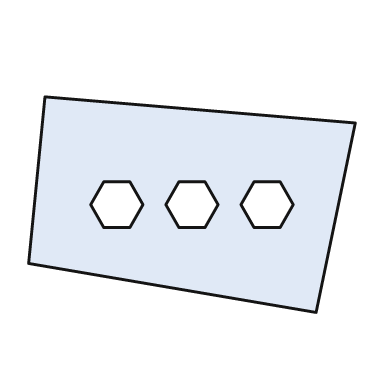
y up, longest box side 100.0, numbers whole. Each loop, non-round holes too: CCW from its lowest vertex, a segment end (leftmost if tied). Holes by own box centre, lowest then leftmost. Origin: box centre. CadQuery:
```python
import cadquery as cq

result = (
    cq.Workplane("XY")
    .moveTo(38.0, -33.0)
    .lineTo(50.0, 25.0)
    .lineTo(-45.0, 33.0)
    .lineTo(-50.0, -18.0)
    .close()
    .moveTo(-27.0, -7.0)
    .lineTo(-19.0, -7.0)
    .lineTo(-15.0, 0.0)
    .lineTo(-19.0, 7.0)
    .lineTo(-27.0, 7.0)
    .lineTo(-31.0, 0.0)
    .close()
    .moveTo(-4.0, -7.0)
    .lineTo(4.0, -7.0)
    .lineTo(8.0, 0.0)
    .lineTo(4.0, 7.0)
    .lineTo(-4.0, 7.0)
    .lineTo(-8.0, 0.0)
    .close()
    .moveTo(19.0, -7.0)
    .lineTo(27.0, -7.0)
    .lineTo(31.0, 0.0)
    .lineTo(27.0, 7.0)
    .lineTo(19.0, 7.0)
    .lineTo(15.0, 0.0)
    .close()
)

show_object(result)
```